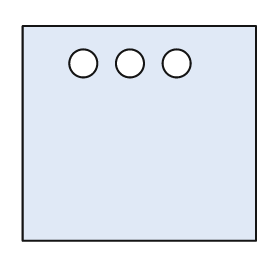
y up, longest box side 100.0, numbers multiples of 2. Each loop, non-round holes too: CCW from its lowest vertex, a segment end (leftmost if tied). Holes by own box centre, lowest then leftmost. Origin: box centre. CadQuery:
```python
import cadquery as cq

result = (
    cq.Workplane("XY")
    .moveTo(-50.0, -46.0)
    .lineTo(50.0, -46.0)
    .lineTo(50.0, 46.0)
    .lineTo(-50.0, 46.0)
    .close()
    .moveTo(-24.0, 30.0)
    .circle(6.0)
    .moveTo(-4.0, 30.0)
    .circle(6.0)
    .moveTo(16.0, 30.0)
    .circle(6.0)
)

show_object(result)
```